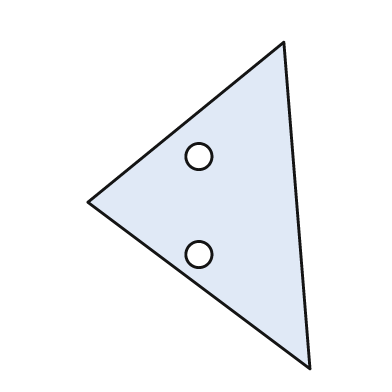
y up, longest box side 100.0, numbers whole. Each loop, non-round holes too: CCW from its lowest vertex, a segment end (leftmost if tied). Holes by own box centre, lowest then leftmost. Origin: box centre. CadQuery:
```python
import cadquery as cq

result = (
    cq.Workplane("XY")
    .moveTo(34.0, -50.0)
    .lineTo(26.0, 50.0)
    .lineTo(-34.0, 1.0)
    .close()
    .moveTo(0.0, -15.0)
    .circle(4.0)
    .moveTo(0.0, 15.0)
    .circle(4.0)
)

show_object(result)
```